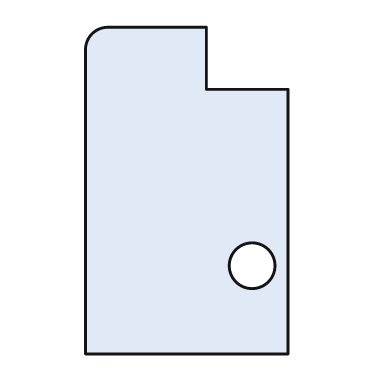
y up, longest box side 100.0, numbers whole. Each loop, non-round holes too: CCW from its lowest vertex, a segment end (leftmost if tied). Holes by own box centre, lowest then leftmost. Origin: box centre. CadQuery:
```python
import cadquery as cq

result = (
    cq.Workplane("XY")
    .moveTo(-31.0, -50.0)
    .lineTo(31.0, -50.0)
    .lineTo(31.0, 31.0)
    .lineTo(6.0, 31.0)
    .lineTo(6.0, 50.0)
    .lineTo(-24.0, 50.0)
    .threePointArc((-29.0, 48.0), (-31.0, 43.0))
    .close()
    .moveTo(20.0, -23.0)
    .circle(7.0)
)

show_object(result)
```